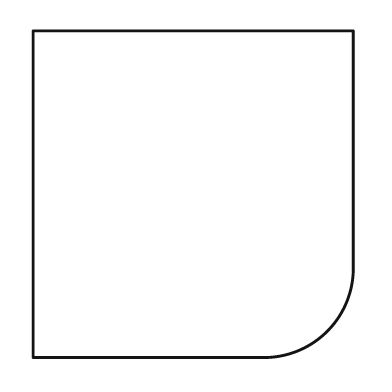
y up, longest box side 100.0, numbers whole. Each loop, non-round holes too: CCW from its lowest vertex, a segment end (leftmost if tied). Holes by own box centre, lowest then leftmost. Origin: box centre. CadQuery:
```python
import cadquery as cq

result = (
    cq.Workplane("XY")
    .moveTo(-49.0, -50.0)
    .lineTo(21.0, -50.0)
    .threePointArc((41.0, -42.0), (49.0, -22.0))
    .lineTo(49.0, 50.0)
    .lineTo(-49.0, 50.0)
    .close()
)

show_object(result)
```